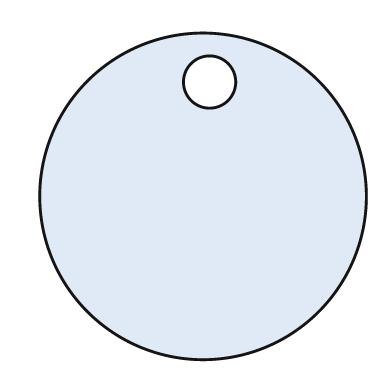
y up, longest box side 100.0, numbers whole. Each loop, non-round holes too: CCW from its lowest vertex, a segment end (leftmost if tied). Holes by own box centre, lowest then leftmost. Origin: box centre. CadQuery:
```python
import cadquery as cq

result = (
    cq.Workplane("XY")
    .moveTo(0.0, 0.0)
    .circle(50.0)
    .moveTo(2.0, 35.0)
    .circle(8.0)
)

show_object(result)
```